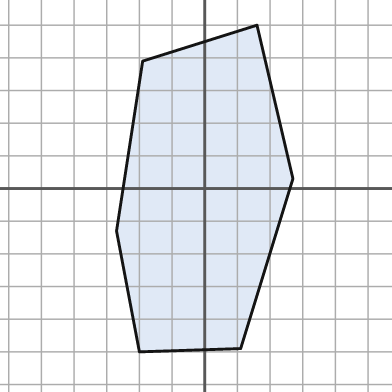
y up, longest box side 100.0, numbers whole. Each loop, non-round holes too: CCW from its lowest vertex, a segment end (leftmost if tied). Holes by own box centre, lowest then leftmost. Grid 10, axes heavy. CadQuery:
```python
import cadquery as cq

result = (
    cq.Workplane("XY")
    .moveTo(-20.0, -50.0)
    .lineTo(11.0, -49.0)
    .lineTo(27.0, 3.0)
    .lineTo(16.0, 50.0)
    .lineTo(-19.0, 39.0)
    .lineTo(-27.0, -13.0)
    .close()
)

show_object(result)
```